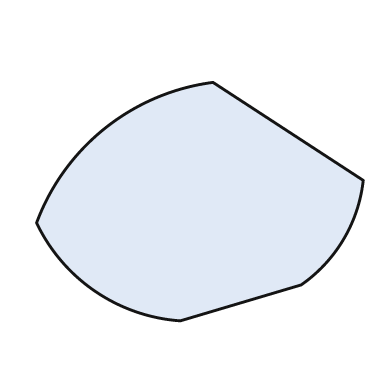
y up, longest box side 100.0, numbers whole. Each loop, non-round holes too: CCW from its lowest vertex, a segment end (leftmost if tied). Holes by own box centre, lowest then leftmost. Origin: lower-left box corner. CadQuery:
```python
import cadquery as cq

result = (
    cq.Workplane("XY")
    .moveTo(44.0, 0.0)
    .lineTo(81.0, 11.0)
    .threePointArc((94.0, 25.0), (100.0, 43.0))
    .lineTo(54.0, 73.0)
    .threePointArc((21.0, 59.0), (0.0, 30.0))
    .threePointArc((18.0, 9.0), (44.0, 0.0))
    .close()
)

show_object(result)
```